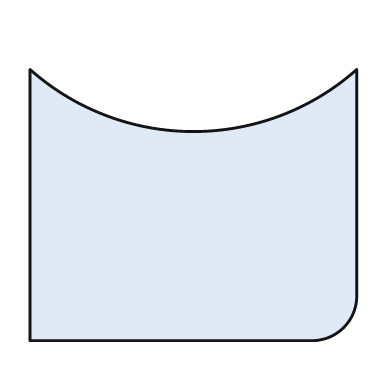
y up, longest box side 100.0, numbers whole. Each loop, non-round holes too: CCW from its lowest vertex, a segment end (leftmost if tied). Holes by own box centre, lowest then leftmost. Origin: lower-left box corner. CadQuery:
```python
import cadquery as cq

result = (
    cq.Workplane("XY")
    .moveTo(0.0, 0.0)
    .lineTo(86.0, 0.0)
    .threePointArc((96.0, 4.0), (100.0, 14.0))
    .lineTo(100.0, 83.0)
    .threePointArc((50.0, 64.0), (0.0, 83.0))
    .close()
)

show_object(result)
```